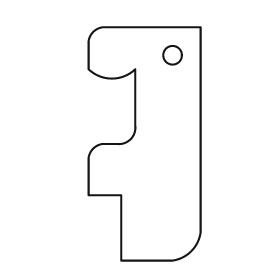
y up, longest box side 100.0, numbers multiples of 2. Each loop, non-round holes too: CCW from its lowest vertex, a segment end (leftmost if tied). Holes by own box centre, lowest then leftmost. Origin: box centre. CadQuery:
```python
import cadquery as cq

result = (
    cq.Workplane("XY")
    .moveTo(-10.0, -50.0)
    .lineTo(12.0, -50.0)
    .threePointArc((20.0, -46.0), (24.0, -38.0))
    .lineTo(24.0, 50.0)
    .lineTo(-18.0, 50.0)
    .threePointArc((-22.0, 48.0), (-24.0, 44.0))
    .lineTo(-24.0, 32.0)
    .threePointArc((-14.0, 28.0), (-4.0, 32.0))
    .lineTo(-4.0, 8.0)
    .threePointArc((-6.0, 2.0), (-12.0, 0.0))
    .lineTo(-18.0, 0.0)
    .threePointArc((-22.0, -2.0), (-24.0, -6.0))
    .lineTo(-24.0, -22.0)
    .lineTo(-10.0, -22.0)
    .close()
    .moveTo(12.0, 38.0)
    .circle(4.0)
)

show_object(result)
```